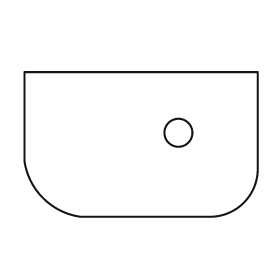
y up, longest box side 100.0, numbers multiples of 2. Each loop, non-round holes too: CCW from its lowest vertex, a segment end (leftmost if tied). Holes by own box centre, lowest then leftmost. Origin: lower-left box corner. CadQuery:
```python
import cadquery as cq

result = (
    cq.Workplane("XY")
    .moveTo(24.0, 0.0)
    .lineTo(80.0, 0.0)
    .threePointArc((94.0, 6.0), (100.0, 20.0))
    .lineTo(100.0, 62.0)
    .lineTo(0.0, 62.0)
    .lineTo(0.0, 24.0)
    .threePointArc((8.0, 8.0), (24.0, 0.0))
    .close()
    .moveTo(66.0, 36.0)
    .circle(6.0)
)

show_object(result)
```